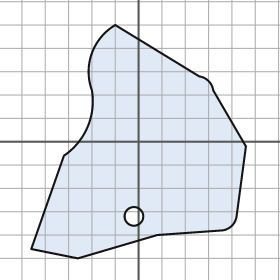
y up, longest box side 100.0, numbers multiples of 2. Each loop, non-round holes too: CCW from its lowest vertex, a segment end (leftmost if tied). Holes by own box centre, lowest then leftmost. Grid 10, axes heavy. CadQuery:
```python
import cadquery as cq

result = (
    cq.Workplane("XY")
    .moveTo(-26.0, -50.0)
    .lineTo(8.0, -40.0)
    .lineTo(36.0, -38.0)
    .threePointArc((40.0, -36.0), (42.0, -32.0))
    .lineTo(46.0, -2.0)
    .lineTo(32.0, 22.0)
    .threePointArc((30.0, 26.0), (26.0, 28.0))
    .lineTo(-10.0, 50.0)
    .threePointArc((-20.0, 38.0), (-20.0, 22.0))
    .threePointArc((-22.0, 6.0), (-32.0, -6.0))
    .lineTo(-46.0, -46.0)
    .close()
    .moveTo(-2.0, -32.0)
    .circle(4.0)
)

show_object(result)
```